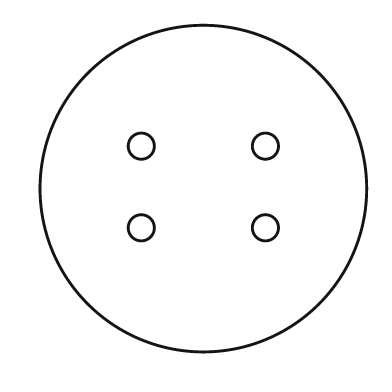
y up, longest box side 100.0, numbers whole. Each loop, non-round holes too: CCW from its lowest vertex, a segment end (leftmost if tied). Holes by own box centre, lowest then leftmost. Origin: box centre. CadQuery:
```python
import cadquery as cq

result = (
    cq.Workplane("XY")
    .moveTo(0.0, 0.0)
    .circle(50.0)
    .moveTo(-19.0, -12.0)
    .circle(4.0)
    .moveTo(19.0, -12.0)
    .circle(4.0)
    .moveTo(-19.0, 13.0)
    .circle(4.0)
    .moveTo(19.0, 13.0)
    .circle(4.0)
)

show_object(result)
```